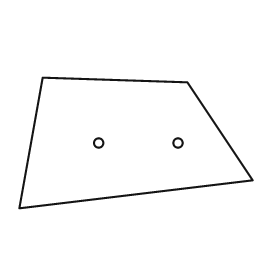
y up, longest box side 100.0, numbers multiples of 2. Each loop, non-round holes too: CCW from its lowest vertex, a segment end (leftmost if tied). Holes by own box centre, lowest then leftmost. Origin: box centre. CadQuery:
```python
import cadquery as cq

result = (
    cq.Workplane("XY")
    .moveTo(-50.0, -28.0)
    .lineTo(50.0, -16.0)
    .lineTo(22.0, 26.0)
    .lineTo(-40.0, 28.0)
    .close()
    .moveTo(-16.0, 0.0)
    .circle(2.0)
    .moveTo(18.0, 0.0)
    .circle(2.0)
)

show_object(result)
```